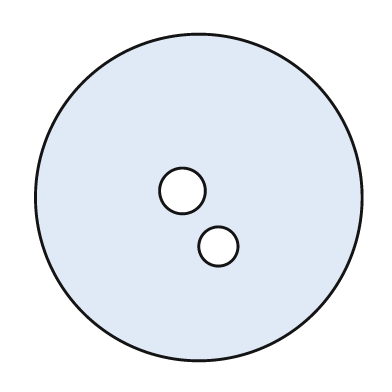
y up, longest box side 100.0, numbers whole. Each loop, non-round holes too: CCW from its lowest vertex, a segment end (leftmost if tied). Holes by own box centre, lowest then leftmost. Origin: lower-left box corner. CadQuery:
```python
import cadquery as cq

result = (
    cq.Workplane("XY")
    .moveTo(50.0, 50.0)
    .circle(50.0)
    .moveTo(56.0, 35.0)
    .circle(6.0)
    .moveTo(45.0, 52.0)
    .circle(7.0)
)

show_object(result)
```